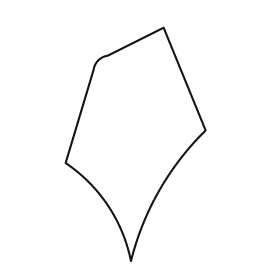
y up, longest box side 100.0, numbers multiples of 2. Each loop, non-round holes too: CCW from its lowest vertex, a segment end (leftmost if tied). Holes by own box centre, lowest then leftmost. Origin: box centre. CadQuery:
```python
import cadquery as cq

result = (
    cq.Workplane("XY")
    .moveTo(-2.0, -50.0)
    .threePointArc((10.0, -20.0), (30.0, 6.0))
    .lineTo(12.0, 50.0)
    .lineTo(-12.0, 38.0)
    .threePointArc((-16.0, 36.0), (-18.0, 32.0))
    .lineTo(-30.0, -8.0)
    .threePointArc((-12.0, -26.0), (-2.0, -50.0))
    .close()
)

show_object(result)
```